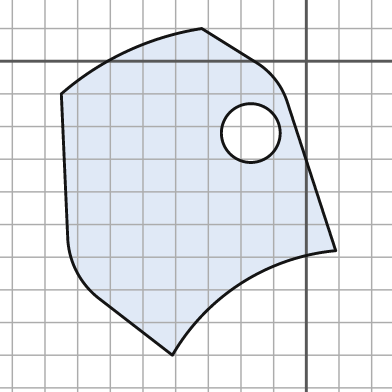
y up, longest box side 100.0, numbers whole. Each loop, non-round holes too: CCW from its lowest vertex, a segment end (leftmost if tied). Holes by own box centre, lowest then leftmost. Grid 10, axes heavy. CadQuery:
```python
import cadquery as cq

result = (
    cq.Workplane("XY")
    .moveTo(-41.0, -90.0)
    .threePointArc((-20.0, -68.0), (9.0, -58.0))
    .lineTo(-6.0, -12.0)
    .threePointArc((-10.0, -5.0), (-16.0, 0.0))
    .lineTo(-32.0, 10.0)
    .threePointArc((-55.0, 3.0), (-75.0, -10.0))
    .lineTo(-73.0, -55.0)
    .threePointArc((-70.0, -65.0), (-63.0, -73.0))
    .close()
    .moveTo(-17.0, -22.0)
    .circle(9.0)
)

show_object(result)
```